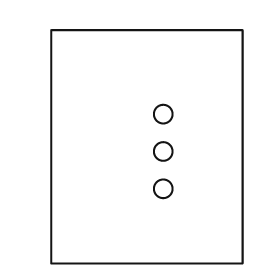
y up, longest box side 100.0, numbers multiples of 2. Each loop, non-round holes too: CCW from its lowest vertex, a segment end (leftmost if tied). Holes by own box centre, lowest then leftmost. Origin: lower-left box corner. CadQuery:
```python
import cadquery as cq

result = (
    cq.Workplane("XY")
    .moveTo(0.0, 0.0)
    .lineTo(82.0, 0.0)
    .lineTo(82.0, 100.0)
    .lineTo(0.0, 100.0)
    .close()
    .moveTo(48.0, 32.0)
    .circle(4.0)
    .moveTo(48.0, 48.0)
    .circle(4.0)
    .moveTo(48.0, 64.0)
    .circle(4.0)
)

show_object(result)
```